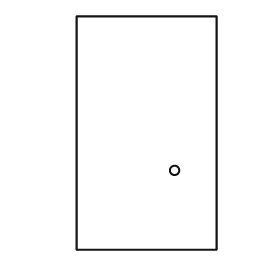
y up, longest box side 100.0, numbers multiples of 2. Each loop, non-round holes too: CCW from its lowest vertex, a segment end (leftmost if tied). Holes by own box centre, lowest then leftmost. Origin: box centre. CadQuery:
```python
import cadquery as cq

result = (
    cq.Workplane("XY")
    .moveTo(-30.0, -50.0)
    .lineTo(30.0, -50.0)
    .lineTo(30.0, 50.0)
    .lineTo(-30.0, 50.0)
    .close()
    .moveTo(12.0, -16.0)
    .circle(2.0)
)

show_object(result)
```